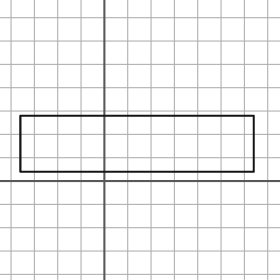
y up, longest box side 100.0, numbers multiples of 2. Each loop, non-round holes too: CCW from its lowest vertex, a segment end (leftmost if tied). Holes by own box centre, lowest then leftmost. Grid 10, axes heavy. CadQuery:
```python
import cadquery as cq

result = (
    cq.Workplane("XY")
    .moveTo(-36.0, 4.0)
    .lineTo(64.0, 4.0)
    .lineTo(64.0, 28.0)
    .lineTo(-36.0, 28.0)
    .close()
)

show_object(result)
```